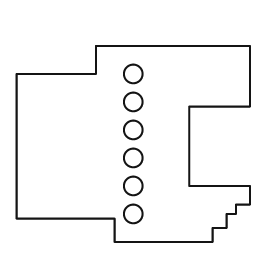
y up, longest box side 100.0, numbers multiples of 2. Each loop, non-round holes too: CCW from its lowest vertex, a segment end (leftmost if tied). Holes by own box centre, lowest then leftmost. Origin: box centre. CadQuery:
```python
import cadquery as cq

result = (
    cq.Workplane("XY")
    .moveTo(-8.0, -42.0)
    .lineTo(34.0, -42.0)
    .lineTo(34.0, -36.0)
    .lineTo(40.0, -36.0)
    .lineTo(40.0, -30.0)
    .lineTo(44.0, -30.0)
    .lineTo(44.0, -26.0)
    .lineTo(50.0, -26.0)
    .lineTo(50.0, -18.0)
    .lineTo(24.0, -18.0)
    .lineTo(24.0, 16.0)
    .lineTo(50.0, 16.0)
    .lineTo(50.0, 42.0)
    .lineTo(-16.0, 42.0)
    .lineTo(-16.0, 30.0)
    .lineTo(-50.0, 30.0)
    .lineTo(-50.0, -32.0)
    .lineTo(-8.0, -32.0)
    .close()
    .moveTo(0.0, -30.0)
    .circle(4.0)
    .moveTo(0.0, -18.0)
    .circle(4.0)
    .moveTo(0.0, -6.0)
    .circle(4.0)
    .moveTo(0.0, 6.0)
    .circle(4.0)
    .moveTo(0.0, 18.0)
    .circle(4.0)
    .moveTo(0.0, 30.0)
    .circle(4.0)
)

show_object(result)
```